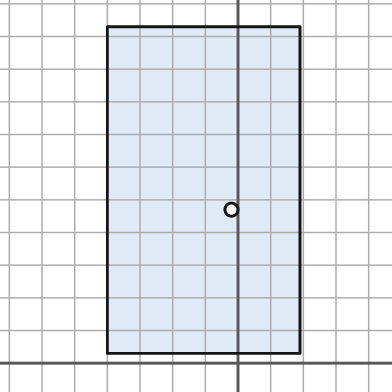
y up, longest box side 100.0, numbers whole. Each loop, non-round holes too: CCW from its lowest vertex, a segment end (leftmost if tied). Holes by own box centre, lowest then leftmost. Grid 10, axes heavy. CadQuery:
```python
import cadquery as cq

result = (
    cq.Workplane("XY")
    .moveTo(-40.0, 3.0)
    .lineTo(19.0, 3.0)
    .lineTo(19.0, 103.0)
    .lineTo(-40.0, 103.0)
    .close()
    .moveTo(-2.0, 47.0)
    .circle(2.0)
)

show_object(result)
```